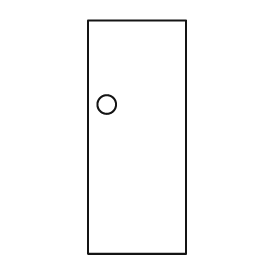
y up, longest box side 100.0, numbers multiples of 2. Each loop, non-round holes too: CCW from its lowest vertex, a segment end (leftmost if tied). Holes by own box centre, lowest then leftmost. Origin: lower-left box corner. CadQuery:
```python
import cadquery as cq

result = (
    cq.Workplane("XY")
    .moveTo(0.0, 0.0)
    .lineTo(42.0, 0.0)
    .lineTo(42.0, 100.0)
    .lineTo(0.0, 100.0)
    .close()
    .moveTo(8.0, 64.0)
    .circle(4.0)
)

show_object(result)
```